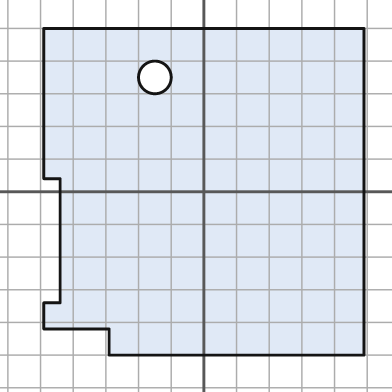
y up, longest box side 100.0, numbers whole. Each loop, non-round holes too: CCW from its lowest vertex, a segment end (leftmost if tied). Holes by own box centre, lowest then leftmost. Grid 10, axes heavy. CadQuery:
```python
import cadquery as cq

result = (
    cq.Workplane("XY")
    .moveTo(-29.0, -50.0)
    .lineTo(49.0, -50.0)
    .lineTo(49.0, 50.0)
    .lineTo(-49.0, 50.0)
    .lineTo(-49.0, 4.0)
    .lineTo(-44.0, 4.0)
    .lineTo(-44.0, -34.0)
    .lineTo(-49.0, -34.0)
    .lineTo(-49.0, -42.0)
    .lineTo(-29.0, -42.0)
    .close()
    .moveTo(-15.0, 35.0)
    .circle(5.0)
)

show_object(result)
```